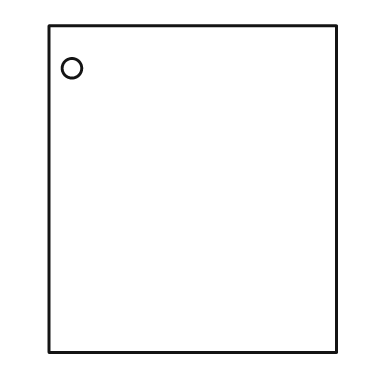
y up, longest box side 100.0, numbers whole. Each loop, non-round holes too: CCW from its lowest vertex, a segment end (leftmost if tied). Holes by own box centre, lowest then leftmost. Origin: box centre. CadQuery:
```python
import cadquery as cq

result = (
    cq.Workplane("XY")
    .moveTo(-44.0, -50.0)
    .lineTo(44.0, -50.0)
    .lineTo(44.0, 50.0)
    .lineTo(-44.0, 50.0)
    .close()
    .moveTo(-37.0, 37.0)
    .circle(3.0)
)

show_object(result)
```